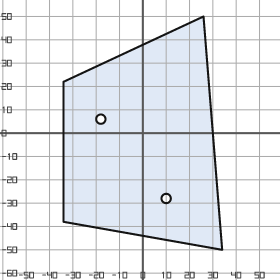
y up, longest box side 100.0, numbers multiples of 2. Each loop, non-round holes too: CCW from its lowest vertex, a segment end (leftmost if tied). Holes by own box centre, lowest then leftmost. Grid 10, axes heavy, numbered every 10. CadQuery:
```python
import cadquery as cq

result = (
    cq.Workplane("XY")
    .moveTo(34.0, -50.0)
    .lineTo(26.0, 50.0)
    .lineTo(-34.0, 22.0)
    .lineTo(-34.0, -38.0)
    .close()
    .moveTo(10.0, -28.0)
    .circle(2.0)
    .moveTo(-18.0, 6.0)
    .circle(2.0)
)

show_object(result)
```